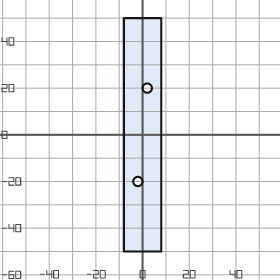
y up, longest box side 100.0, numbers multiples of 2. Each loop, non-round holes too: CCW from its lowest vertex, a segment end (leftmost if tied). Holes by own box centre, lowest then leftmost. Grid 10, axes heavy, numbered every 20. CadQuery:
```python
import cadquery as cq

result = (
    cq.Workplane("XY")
    .moveTo(-8.0, -50.0)
    .lineTo(8.0, -50.0)
    .lineTo(8.0, 50.0)
    .lineTo(-8.0, 50.0)
    .close()
    .moveTo(-2.0, -20.0)
    .circle(2.0)
    .moveTo(2.0, 20.0)
    .circle(2.0)
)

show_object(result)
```